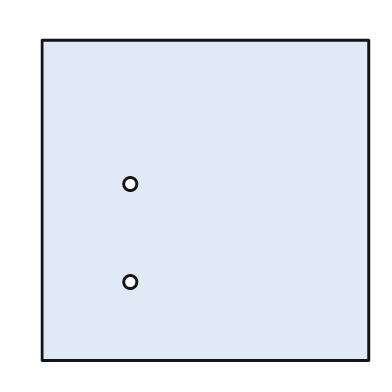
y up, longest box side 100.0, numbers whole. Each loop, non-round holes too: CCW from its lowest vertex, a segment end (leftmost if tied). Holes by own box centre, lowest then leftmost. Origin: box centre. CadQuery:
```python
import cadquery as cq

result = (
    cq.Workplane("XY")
    .moveTo(-50.0, -49.0)
    .lineTo(50.0, -49.0)
    .lineTo(50.0, 49.0)
    .lineTo(-50.0, 49.0)
    .close()
    .moveTo(-23.0, -25.0)
    .circle(2.0)
    .moveTo(-23.0, 5.0)
    .circle(2.0)
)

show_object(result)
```